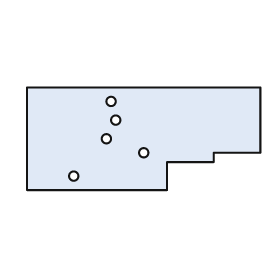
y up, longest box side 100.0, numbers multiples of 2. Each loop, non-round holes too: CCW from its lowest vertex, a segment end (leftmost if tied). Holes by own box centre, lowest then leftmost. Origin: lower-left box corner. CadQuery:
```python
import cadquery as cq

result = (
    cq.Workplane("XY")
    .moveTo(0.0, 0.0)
    .lineTo(60.0, 0.0)
    .lineTo(60.0, 12.0)
    .lineTo(80.0, 12.0)
    .lineTo(80.0, 16.0)
    .lineTo(100.0, 16.0)
    .lineTo(100.0, 44.0)
    .lineTo(0.0, 44.0)
    .close()
    .moveTo(20.0, 6.0)
    .circle(2.0)
    .moveTo(50.0, 16.0)
    .circle(2.0)
    .moveTo(34.0, 22.0)
    .circle(2.0)
    .moveTo(38.0, 30.0)
    .circle(2.0)
    .moveTo(36.0, 38.0)
    .circle(2.0)
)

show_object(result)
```